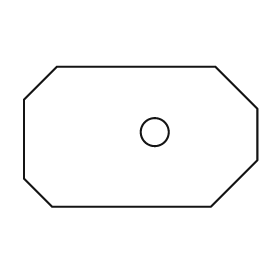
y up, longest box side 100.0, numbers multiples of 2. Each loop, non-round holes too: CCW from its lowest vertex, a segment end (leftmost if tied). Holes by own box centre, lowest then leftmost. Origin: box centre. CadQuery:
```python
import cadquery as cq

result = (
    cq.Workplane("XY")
    .moveTo(-38.0, -30.0)
    .lineTo(30.0, -30.0)
    .lineTo(50.0, -10.0)
    .lineTo(50.0, 12.0)
    .lineTo(32.0, 30.0)
    .lineTo(-36.0, 30.0)
    .lineTo(-50.0, 16.0)
    .lineTo(-50.0, -18.0)
    .close()
    .moveTo(6.0, 2.0)
    .circle(6.0)
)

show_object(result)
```